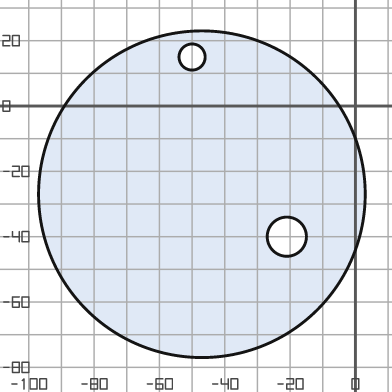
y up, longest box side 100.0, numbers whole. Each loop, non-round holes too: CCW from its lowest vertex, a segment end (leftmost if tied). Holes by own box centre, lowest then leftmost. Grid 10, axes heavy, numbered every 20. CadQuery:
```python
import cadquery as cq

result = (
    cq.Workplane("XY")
    .moveTo(-47.0, -27.0)
    .circle(50.0)
    .moveTo(-21.0, -40.0)
    .circle(6.0)
    .moveTo(-50.0, 15.0)
    .circle(4.0)
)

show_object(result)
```